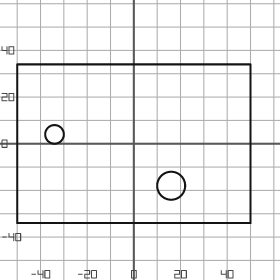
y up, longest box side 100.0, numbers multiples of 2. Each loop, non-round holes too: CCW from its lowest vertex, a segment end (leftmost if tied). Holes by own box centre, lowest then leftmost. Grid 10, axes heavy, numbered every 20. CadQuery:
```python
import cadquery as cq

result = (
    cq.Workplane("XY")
    .moveTo(-50.0, -34.0)
    .lineTo(50.0, -34.0)
    .lineTo(50.0, 34.0)
    .lineTo(-50.0, 34.0)
    .close()
    .moveTo(16.0, -18.0)
    .circle(6.0)
    .moveTo(-34.0, 4.0)
    .circle(4.0)
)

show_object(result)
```